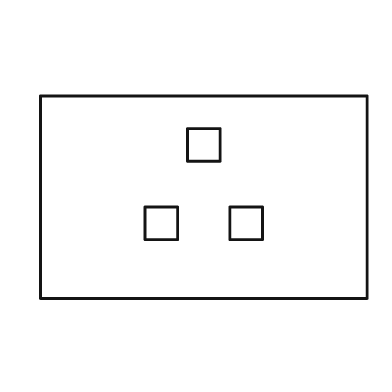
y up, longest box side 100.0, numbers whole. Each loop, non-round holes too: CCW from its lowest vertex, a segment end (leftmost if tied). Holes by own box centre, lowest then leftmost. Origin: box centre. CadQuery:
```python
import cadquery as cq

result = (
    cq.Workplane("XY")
    .moveTo(-50.0, -31.0)
    .lineTo(50.0, -31.0)
    .lineTo(50.0, 31.0)
    .lineTo(-50.0, 31.0)
    .close()
    .moveTo(-18.0, -13.0)
    .lineTo(-8.0, -13.0)
    .lineTo(-8.0, -3.0)
    .lineTo(-18.0, -3.0)
    .close()
    .moveTo(8.0, -13.0)
    .lineTo(18.0, -13.0)
    .lineTo(18.0, -3.0)
    .lineTo(8.0, -3.0)
    .close()
    .moveTo(-5.0, 11.0)
    .lineTo(5.0, 11.0)
    .lineTo(5.0, 21.0)
    .lineTo(-5.0, 21.0)
    .close()
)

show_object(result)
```